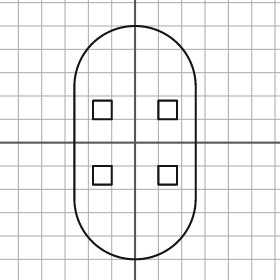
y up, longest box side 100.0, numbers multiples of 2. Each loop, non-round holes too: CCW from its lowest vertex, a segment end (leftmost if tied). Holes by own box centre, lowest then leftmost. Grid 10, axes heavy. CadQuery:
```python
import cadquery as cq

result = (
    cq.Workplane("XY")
    .moveTo(-26.0, -24.0)
    .threePointArc((0.0, -50.0), (26.0, -24.0))
    .lineTo(26.0, 24.0)
    .threePointArc((0.0, 50.0), (-26.0, 24.0))
    .close()
    .moveTo(-18.0, -18.0)
    .lineTo(-10.0, -18.0)
    .lineTo(-10.0, -10.0)
    .lineTo(-18.0, -10.0)
    .close()
    .moveTo(10.0, -18.0)
    .lineTo(18.0, -18.0)
    .lineTo(18.0, -10.0)
    .lineTo(10.0, -10.0)
    .close()
    .moveTo(-18.0, 10.0)
    .lineTo(-10.0, 10.0)
    .lineTo(-10.0, 18.0)
    .lineTo(-18.0, 18.0)
    .close()
    .moveTo(10.0, 10.0)
    .lineTo(18.0, 10.0)
    .lineTo(18.0, 18.0)
    .lineTo(10.0, 18.0)
    .close()
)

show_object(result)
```